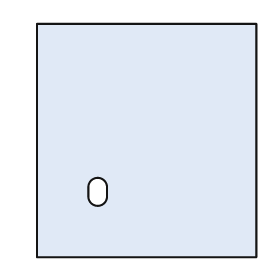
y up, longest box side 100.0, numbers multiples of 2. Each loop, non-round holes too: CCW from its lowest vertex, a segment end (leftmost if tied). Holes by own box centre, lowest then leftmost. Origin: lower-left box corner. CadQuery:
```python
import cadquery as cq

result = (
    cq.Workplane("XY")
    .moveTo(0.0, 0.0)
    .lineTo(94.0, 0.0)
    .lineTo(94.0, 100.0)
    .lineTo(0.0, 100.0)
    .close()
    .moveTo(22.0, 26.0)
    .threePointArc((26.0, 22.0), (30.0, 26.0))
    .lineTo(30.0, 30.0)
    .threePointArc((26.0, 34.0), (22.0, 30.0))
    .close()
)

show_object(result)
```